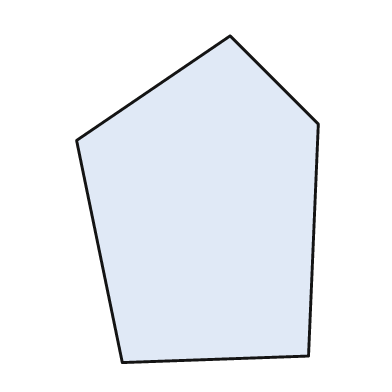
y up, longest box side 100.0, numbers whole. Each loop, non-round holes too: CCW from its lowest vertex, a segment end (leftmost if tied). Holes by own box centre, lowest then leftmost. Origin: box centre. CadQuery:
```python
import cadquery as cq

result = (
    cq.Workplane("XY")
    .moveTo(-23.0, -50.0)
    .lineTo(34.0, -48.0)
    .lineTo(37.0, 23.0)
    .lineTo(10.0, 50.0)
    .lineTo(-37.0, 18.0)
    .close()
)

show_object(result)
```